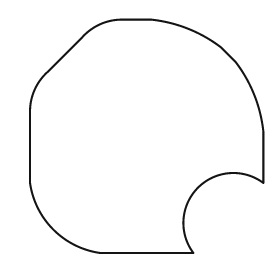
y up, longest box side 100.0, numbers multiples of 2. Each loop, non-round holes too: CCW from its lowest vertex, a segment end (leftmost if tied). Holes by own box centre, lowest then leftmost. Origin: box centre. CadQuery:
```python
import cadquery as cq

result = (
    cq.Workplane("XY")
    .moveTo(-20.0, -50.0)
    .lineTo(20.0, -50.0)
    .threePointArc((22.0, -22.0), (50.0, -20.0))
    .lineTo(50.0, 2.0)
    .threePointArc((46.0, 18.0), (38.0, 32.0))
    .lineTo(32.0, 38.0)
    .threePointArc((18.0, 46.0), (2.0, 50.0))
    .lineTo(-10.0, 50.0)
    .threePointArc((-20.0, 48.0), (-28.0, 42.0))
    .lineTo(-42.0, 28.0)
    .threePointArc((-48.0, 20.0), (-50.0, 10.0))
    .lineTo(-50.0, -20.0)
    .threePointArc((-40.0, -40.0), (-20.0, -50.0))
    .close()
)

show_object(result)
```